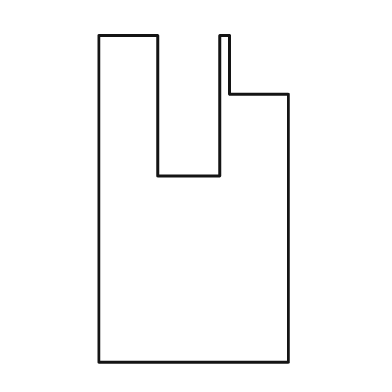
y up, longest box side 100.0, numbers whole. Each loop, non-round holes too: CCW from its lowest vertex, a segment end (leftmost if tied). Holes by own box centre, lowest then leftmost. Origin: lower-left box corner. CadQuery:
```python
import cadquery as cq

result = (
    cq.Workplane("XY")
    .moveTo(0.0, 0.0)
    .lineTo(58.0, 0.0)
    .lineTo(58.0, 82.0)
    .lineTo(40.0, 82.0)
    .lineTo(40.0, 100.0)
    .lineTo(37.0, 100.0)
    .lineTo(37.0, 57.0)
    .lineTo(18.0, 57.0)
    .lineTo(18.0, 100.0)
    .lineTo(0.0, 100.0)
    .close()
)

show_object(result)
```